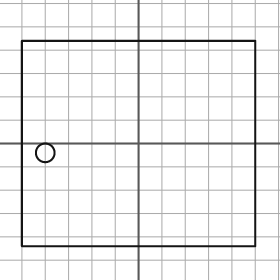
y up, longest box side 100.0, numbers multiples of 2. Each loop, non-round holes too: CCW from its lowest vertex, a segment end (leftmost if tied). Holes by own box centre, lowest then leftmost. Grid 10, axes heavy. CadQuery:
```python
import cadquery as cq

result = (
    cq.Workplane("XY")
    .moveTo(-50.0, -44.0)
    .lineTo(50.0, -44.0)
    .lineTo(50.0, 44.0)
    .lineTo(-50.0, 44.0)
    .close()
    .moveTo(-40.0, -4.0)
    .circle(4.0)
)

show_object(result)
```